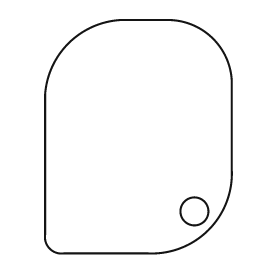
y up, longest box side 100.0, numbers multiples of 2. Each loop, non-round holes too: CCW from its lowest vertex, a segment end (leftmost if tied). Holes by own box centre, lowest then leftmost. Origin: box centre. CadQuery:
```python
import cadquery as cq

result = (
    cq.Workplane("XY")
    .moveTo(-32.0, -50.0)
    .lineTo(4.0, -50.0)
    .threePointArc((30.0, -40.0), (40.0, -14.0))
    .lineTo(40.0, 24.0)
    .threePointArc((32.0, 42.0), (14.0, 50.0))
    .lineTo(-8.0, 50.0)
    .threePointArc((-30.0, 40.0), (-40.0, 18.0))
    .lineTo(-40.0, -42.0)
    .threePointArc((-38.0, -48.0), (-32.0, -50.0))
    .close()
    .moveTo(24.0, -32.0)
    .circle(6.0)
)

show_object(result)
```